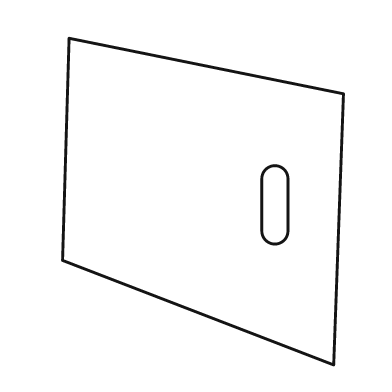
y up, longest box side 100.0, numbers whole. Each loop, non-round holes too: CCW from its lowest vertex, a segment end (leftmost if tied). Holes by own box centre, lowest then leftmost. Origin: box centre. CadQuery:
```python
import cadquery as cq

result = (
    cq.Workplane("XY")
    .moveTo(40.0, -50.0)
    .lineTo(43.0, 33.0)
    .lineTo(-41.0, 50.0)
    .lineTo(-43.0, -18.0)
    .close()
    .moveTo(18.0, -9.0)
    .threePointArc((22.0, -13.0), (26.0, -9.0))
    .lineTo(26.0, 7.0)
    .threePointArc((22.0, 11.0), (18.0, 7.0))
    .close()
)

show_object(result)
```